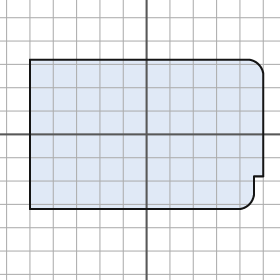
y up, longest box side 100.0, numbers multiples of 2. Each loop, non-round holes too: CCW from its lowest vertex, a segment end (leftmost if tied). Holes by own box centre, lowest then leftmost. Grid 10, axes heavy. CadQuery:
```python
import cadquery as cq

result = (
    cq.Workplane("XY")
    .moveTo(-50.0, -32.0)
    .lineTo(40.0, -32.0)
    .threePointArc((44.0, -30.0), (46.0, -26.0))
    .lineTo(46.0, -18.0)
    .lineTo(50.0, -18.0)
    .lineTo(50.0, 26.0)
    .threePointArc((48.0, 30.0), (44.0, 32.0))
    .lineTo(-50.0, 32.0)
    .close()
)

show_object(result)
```